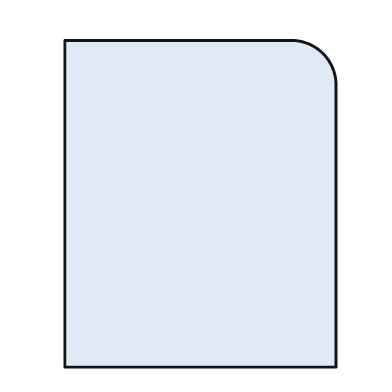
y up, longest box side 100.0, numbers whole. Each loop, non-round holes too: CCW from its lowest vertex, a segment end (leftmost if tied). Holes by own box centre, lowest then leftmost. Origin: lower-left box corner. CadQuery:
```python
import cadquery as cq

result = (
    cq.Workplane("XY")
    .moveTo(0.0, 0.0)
    .lineTo(83.0, 0.0)
    .lineTo(83.0, 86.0)
    .threePointArc((79.0, 96.0), (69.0, 100.0))
    .lineTo(0.0, 100.0)
    .close()
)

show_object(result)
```